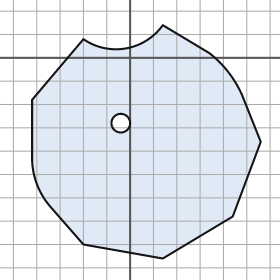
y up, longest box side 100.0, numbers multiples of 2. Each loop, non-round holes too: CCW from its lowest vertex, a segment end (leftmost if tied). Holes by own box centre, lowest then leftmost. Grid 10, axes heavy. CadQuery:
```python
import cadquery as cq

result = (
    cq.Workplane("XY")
    .moveTo(14.0, -86.0)
    .lineTo(44.0, -68.0)
    .lineTo(56.0, -36.0)
    .lineTo(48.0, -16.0)
    .threePointArc((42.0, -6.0), (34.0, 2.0))
    .lineTo(14.0, 14.0)
    .threePointArc((-2.0, 4.0), (-20.0, 8.0))
    .lineTo(-42.0, -18.0)
    .lineTo(-42.0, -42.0)
    .threePointArc((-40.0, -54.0), (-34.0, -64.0))
    .lineTo(-20.0, -80.0)
    .close()
    .moveTo(-4.0, -28.0)
    .circle(4.0)
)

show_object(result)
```